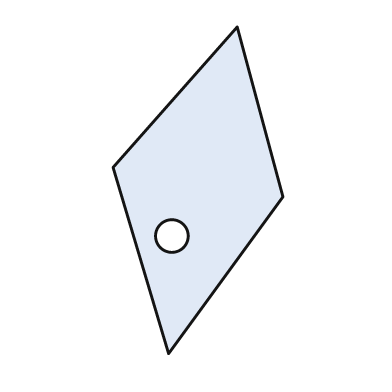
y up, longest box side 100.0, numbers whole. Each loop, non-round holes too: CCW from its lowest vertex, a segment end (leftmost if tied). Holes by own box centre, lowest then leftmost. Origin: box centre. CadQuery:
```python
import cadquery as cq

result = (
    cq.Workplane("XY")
    .moveTo(-9.0, -50.0)
    .lineTo(26.0, -2.0)
    .lineTo(12.0, 50.0)
    .lineTo(-26.0, 7.0)
    .close()
    .moveTo(-8.0, -14.0)
    .circle(5.0)
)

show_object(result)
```